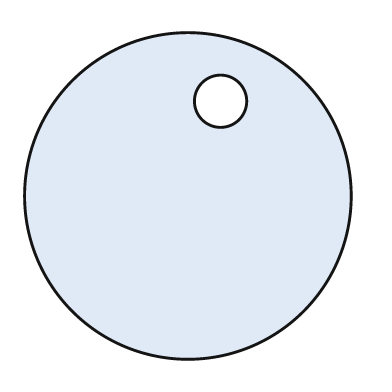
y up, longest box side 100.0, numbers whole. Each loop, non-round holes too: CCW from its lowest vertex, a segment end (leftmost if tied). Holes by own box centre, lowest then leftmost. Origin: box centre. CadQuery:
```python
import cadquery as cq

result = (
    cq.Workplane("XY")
    .moveTo(0.0, 0.0)
    .circle(50.0)
    .moveTo(10.0, 29.0)
    .circle(8.0)
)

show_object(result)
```